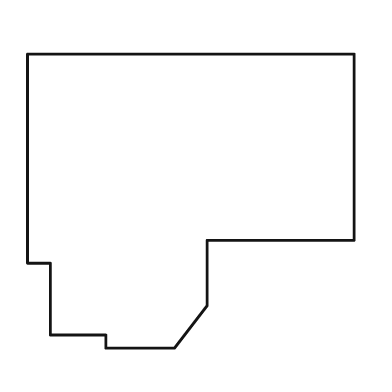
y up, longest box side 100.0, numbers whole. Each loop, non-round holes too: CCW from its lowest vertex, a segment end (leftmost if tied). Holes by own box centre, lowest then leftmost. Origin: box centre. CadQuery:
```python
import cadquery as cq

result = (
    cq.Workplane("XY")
    .moveTo(-26.0, -45.0)
    .lineTo(-5.0, -45.0)
    .lineTo(5.0, -32.0)
    .lineTo(5.0, -12.0)
    .lineTo(50.0, -12.0)
    .lineTo(50.0, 45.0)
    .lineTo(-50.0, 45.0)
    .lineTo(-50.0, -19.0)
    .lineTo(-43.0, -19.0)
    .lineTo(-43.0, -41.0)
    .lineTo(-26.0, -41.0)
    .close()
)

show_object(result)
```